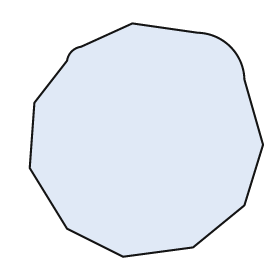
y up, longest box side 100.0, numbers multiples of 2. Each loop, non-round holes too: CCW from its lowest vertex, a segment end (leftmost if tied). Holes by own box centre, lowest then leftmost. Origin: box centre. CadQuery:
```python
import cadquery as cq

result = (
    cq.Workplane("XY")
    .moveTo(-10.0, -50.0)
    .lineTo(20.0, -46.0)
    .lineTo(42.0, -28.0)
    .lineTo(50.0, -2.0)
    .lineTo(42.0, 26.0)
    .threePointArc((36.0, 40.0), (22.0, 46.0))
    .lineTo(-6.0, 50.0)
    .lineTo(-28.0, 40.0)
    .threePointArc((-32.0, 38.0), (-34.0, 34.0))
    .lineTo(-48.0, 16.0)
    .lineTo(-50.0, -12.0)
    .lineTo(-34.0, -38.0)
    .close()
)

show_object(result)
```